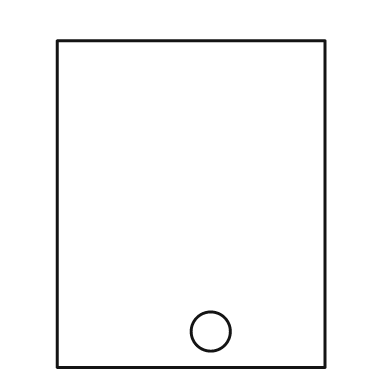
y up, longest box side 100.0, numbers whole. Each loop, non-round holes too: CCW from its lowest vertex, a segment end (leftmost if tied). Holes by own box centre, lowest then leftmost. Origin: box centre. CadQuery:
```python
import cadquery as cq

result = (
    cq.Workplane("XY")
    .moveTo(-41.0, -50.0)
    .lineTo(41.0, -50.0)
    .lineTo(41.0, 50.0)
    .lineTo(-41.0, 50.0)
    .close()
    .moveTo(6.0, -39.0)
    .circle(6.0)
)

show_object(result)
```